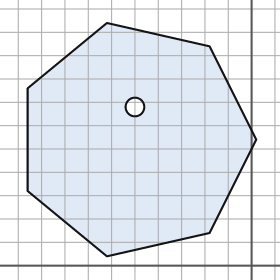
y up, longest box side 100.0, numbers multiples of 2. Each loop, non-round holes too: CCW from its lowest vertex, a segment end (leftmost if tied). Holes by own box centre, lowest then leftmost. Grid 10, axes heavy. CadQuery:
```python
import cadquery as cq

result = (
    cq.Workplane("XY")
    .moveTo(-62.0, 4.0)
    .lineTo(-18.0, 14.0)
    .lineTo(2.0, 54.0)
    .lineTo(-18.0, 94.0)
    .lineTo(-62.0, 104.0)
    .lineTo(-96.0, 76.0)
    .lineTo(-96.0, 32.0)
    .close()
    .moveTo(-50.0, 68.0)
    .circle(4.0)
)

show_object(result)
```